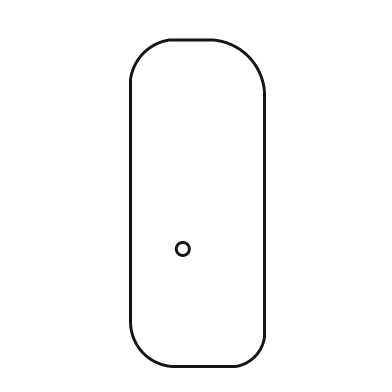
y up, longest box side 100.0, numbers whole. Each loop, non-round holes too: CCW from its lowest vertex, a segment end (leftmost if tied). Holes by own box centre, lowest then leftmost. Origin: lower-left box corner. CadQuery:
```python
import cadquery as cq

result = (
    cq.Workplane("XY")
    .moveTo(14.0, 0.0)
    .lineTo(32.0, 0.0)
    .threePointArc((38.0, 3.0), (41.0, 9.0))
    .lineTo(41.0, 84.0)
    .threePointArc((36.0, 95.0), (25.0, 100.0))
    .lineTo(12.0, 100.0)
    .threePointArc((4.0, 96.0), (0.0, 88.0))
    .lineTo(0.0, 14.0)
    .threePointArc((4.0, 4.0), (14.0, 0.0))
    .close()
    .moveTo(16.0, 36.0)
    .circle(2.0)
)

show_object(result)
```